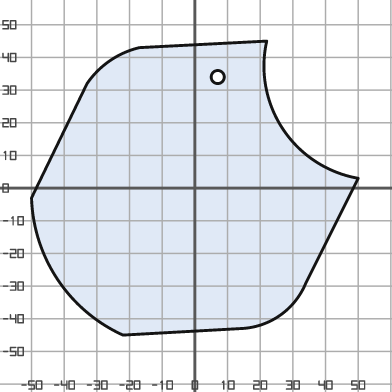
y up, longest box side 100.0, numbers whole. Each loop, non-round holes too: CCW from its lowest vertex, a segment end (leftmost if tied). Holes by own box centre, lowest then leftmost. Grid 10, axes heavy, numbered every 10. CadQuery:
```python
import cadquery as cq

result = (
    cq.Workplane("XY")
    .moveTo(-22.0, -45.0)
    .lineTo(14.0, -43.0)
    .threePointArc((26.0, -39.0), (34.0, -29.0))
    .lineTo(50.0, 3.0)
    .threePointArc((27.0, 18.0), (22.0, 45.0))
    .lineTo(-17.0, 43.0)
    .threePointArc((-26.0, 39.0), (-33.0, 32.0))
    .lineTo(-50.0, -3.0)
    .threePointArc((-42.0, -28.0), (-22.0, -45.0))
    .close()
    .moveTo(7.0, 34.0)
    .circle(2.0)
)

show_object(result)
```